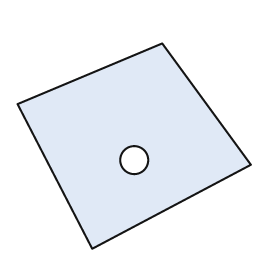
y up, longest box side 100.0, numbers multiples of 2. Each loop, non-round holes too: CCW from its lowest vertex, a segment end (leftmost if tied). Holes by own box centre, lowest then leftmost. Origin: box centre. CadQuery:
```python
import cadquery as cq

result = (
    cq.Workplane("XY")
    .moveTo(-18.0, -44.0)
    .lineTo(50.0, -8.0)
    .lineTo(12.0, 44.0)
    .lineTo(-50.0, 18.0)
    .close()
    .moveTo(0.0, -6.0)
    .circle(6.0)
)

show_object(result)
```